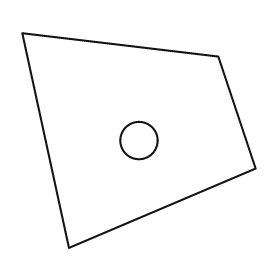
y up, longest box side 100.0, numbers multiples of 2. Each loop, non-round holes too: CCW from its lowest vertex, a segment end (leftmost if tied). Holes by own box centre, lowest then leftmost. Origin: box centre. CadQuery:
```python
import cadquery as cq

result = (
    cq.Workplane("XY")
    .moveTo(-30.0, -46.0)
    .lineTo(50.0, -12.0)
    .lineTo(34.0, 36.0)
    .lineTo(-50.0, 46.0)
    .close()
    .moveTo(0.0, 0.0)
    .circle(8.0)
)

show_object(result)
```